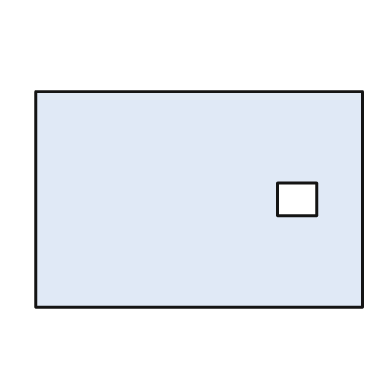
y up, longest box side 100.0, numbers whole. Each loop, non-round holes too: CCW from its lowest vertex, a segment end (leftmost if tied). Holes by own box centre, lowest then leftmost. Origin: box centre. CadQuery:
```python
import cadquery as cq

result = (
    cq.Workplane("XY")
    .moveTo(-50.0, -33.0)
    .lineTo(50.0, -33.0)
    .lineTo(50.0, 33.0)
    .lineTo(-50.0, 33.0)
    .close()
    .moveTo(24.0, -5.0)
    .lineTo(36.0, -5.0)
    .lineTo(36.0, 5.0)
    .lineTo(24.0, 5.0)
    .close()
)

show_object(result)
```